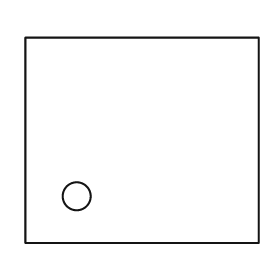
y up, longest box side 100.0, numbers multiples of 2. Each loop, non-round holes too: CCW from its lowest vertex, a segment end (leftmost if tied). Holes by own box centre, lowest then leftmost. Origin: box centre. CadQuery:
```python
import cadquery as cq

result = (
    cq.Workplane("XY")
    .moveTo(-50.0, -44.0)
    .lineTo(50.0, -44.0)
    .lineTo(50.0, 44.0)
    .lineTo(-50.0, 44.0)
    .close()
    .moveTo(-28.0, -24.0)
    .circle(6.0)
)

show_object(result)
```